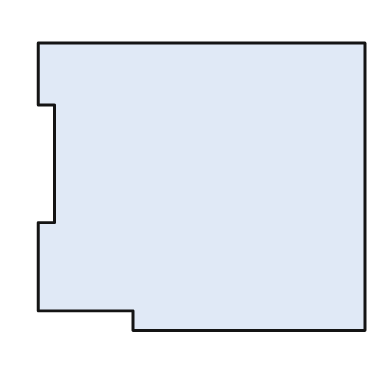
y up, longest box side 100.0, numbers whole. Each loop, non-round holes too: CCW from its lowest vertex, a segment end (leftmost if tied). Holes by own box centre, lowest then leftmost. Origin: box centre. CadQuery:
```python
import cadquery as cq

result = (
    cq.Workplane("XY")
    .moveTo(-21.0, -44.0)
    .lineTo(50.0, -44.0)
    .lineTo(50.0, 44.0)
    .lineTo(-50.0, 44.0)
    .lineTo(-50.0, 25.0)
    .lineTo(-45.0, 25.0)
    .lineTo(-45.0, -11.0)
    .lineTo(-50.0, -11.0)
    .lineTo(-50.0, -38.0)
    .lineTo(-21.0, -38.0)
    .close()
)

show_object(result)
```